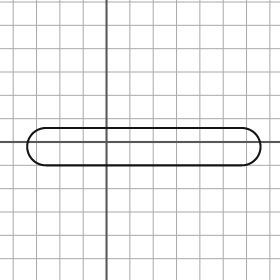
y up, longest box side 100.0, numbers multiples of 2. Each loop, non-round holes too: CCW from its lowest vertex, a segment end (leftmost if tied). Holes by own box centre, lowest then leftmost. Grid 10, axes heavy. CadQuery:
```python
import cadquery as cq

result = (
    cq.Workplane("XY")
    .moveTo(-26.0, -10.0)
    .lineTo(58.0, -10.0)
    .threePointArc((66.0, -2.0), (58.0, 6.0))
    .lineTo(-26.0, 6.0)
    .threePointArc((-34.0, -2.0), (-26.0, -10.0))
    .close()
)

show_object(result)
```